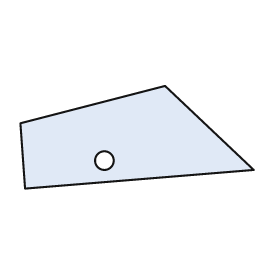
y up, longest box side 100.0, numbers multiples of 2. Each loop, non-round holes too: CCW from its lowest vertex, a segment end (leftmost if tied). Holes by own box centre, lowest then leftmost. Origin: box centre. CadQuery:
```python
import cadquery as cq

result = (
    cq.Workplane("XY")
    .moveTo(-48.0, -22.0)
    .lineTo(50.0, -14.0)
    .lineTo(12.0, 22.0)
    .lineTo(-50.0, 6.0)
    .close()
    .moveTo(-14.0, -10.0)
    .circle(4.0)
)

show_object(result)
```